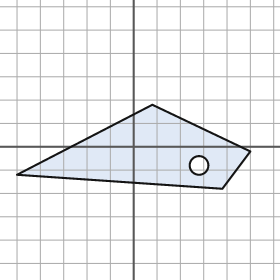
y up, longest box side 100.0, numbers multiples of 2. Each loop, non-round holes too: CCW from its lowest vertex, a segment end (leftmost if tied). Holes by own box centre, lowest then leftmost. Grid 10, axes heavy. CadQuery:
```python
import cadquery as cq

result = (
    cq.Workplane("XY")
    .moveTo(38.0, -18.0)
    .lineTo(50.0, -2.0)
    .lineTo(8.0, 18.0)
    .lineTo(-50.0, -12.0)
    .close()
    .moveTo(28.0, -8.0)
    .circle(4.0)
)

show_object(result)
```